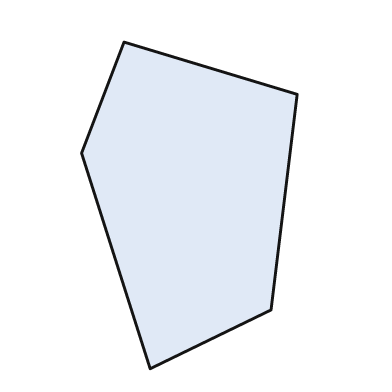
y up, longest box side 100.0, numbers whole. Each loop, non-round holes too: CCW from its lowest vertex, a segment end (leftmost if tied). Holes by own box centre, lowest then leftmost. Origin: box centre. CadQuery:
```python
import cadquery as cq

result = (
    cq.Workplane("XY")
    .moveTo(-12.0, -50.0)
    .lineTo(25.0, -32.0)
    .lineTo(33.0, 34.0)
    .lineTo(-20.0, 50.0)
    .lineTo(-33.0, 16.0)
    .close()
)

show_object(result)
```